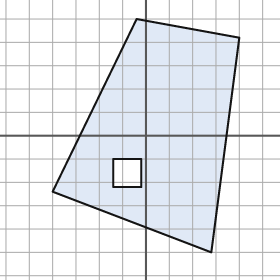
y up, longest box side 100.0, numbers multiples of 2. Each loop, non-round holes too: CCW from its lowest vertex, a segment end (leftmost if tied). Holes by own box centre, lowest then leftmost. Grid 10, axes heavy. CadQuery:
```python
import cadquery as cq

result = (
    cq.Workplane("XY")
    .moveTo(28.0, -50.0)
    .lineTo(40.0, 42.0)
    .lineTo(-4.0, 50.0)
    .lineTo(-40.0, -24.0)
    .close()
    .moveTo(-14.0, -22.0)
    .lineTo(-2.0, -22.0)
    .lineTo(-2.0, -10.0)
    .lineTo(-14.0, -10.0)
    .close()
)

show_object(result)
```